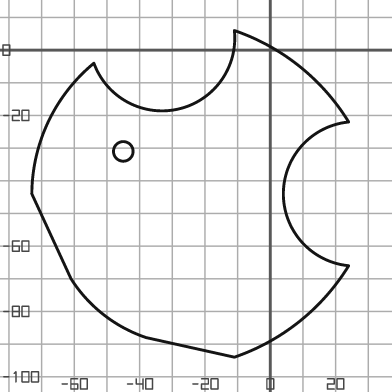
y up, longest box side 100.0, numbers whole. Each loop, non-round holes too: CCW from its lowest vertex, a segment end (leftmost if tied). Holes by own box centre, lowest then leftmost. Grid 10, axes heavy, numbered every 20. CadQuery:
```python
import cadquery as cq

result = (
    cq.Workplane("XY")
    .moveTo(-11.0, -94.0)
    .threePointArc((9.0, -83.0), (24.0, -66.0))
    .threePointArc((4.0, -44.0), (24.0, -22.0))
    .threePointArc((9.0, -5.0), (-11.0, 6.0))
    .threePointArc((-28.0, -18.0), (-54.0, -4.0))
    .threePointArc((-68.0, -22.0), (-73.0, -44.0))
    .lineTo(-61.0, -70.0)
    .threePointArc((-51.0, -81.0), (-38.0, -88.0))
    .close()
    .moveTo(-45.0, -31.0)
    .circle(3.0)
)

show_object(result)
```